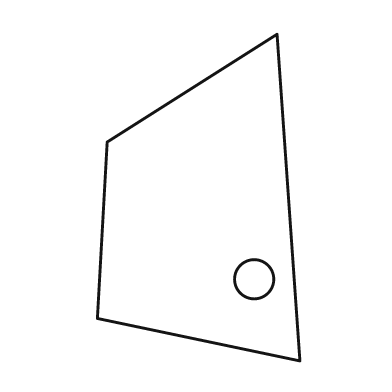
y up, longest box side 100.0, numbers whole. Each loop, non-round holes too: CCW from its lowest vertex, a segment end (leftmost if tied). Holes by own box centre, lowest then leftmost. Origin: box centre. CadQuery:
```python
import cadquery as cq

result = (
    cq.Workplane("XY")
    .moveTo(31.0, -50.0)
    .lineTo(24.0, 50.0)
    .lineTo(-28.0, 17.0)
    .lineTo(-31.0, -37.0)
    .close()
    .moveTo(17.0, -25.0)
    .circle(6.0)
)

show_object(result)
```